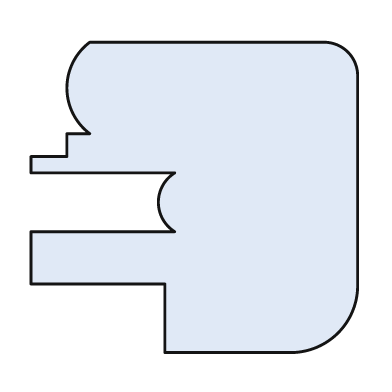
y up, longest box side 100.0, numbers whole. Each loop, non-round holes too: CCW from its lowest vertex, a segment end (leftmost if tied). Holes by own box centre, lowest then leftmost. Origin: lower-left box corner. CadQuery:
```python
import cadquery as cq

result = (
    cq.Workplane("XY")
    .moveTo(41.0, 0.0)
    .lineTo(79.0, 0.0)
    .threePointArc((94.0, 6.0), (100.0, 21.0))
    .lineTo(100.0, 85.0)
    .threePointArc((97.0, 92.0), (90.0, 95.0))
    .lineTo(18.0, 95.0)
    .threePointArc((11.0, 81.0), (18.0, 67.0))
    .lineTo(11.0, 67.0)
    .lineTo(11.0, 60.0)
    .lineTo(0.0, 60.0)
    .lineTo(0.0, 55.0)
    .lineTo(44.0, 55.0)
    .threePointArc((39.0, 46.0), (44.0, 37.0))
    .lineTo(0.0, 37.0)
    .lineTo(0.0, 21.0)
    .lineTo(41.0, 21.0)
    .close()
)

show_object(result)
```